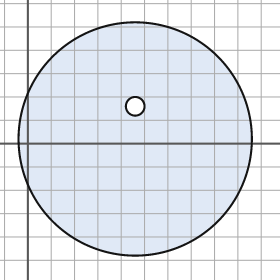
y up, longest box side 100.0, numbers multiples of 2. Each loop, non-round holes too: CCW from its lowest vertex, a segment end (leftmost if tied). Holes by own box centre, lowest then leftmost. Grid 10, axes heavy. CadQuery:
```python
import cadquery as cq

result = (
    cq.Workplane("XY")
    .moveTo(46.0, 2.0)
    .circle(50.0)
    .moveTo(46.0, 16.0)
    .circle(4.0)
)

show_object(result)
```